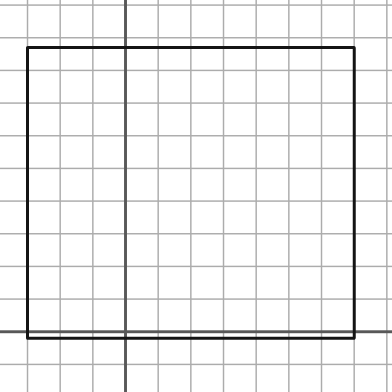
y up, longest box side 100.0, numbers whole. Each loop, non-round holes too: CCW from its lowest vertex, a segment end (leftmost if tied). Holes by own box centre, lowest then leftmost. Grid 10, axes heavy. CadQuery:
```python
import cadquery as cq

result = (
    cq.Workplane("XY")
    .moveTo(-30.0, -2.0)
    .lineTo(70.0, -2.0)
    .lineTo(70.0, 87.0)
    .lineTo(-30.0, 87.0)
    .close()
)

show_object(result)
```